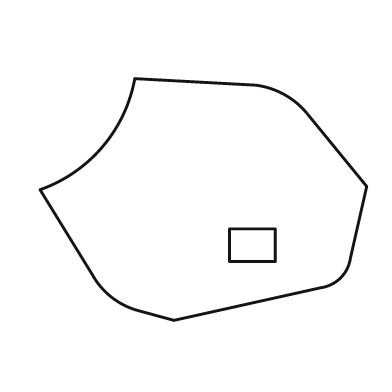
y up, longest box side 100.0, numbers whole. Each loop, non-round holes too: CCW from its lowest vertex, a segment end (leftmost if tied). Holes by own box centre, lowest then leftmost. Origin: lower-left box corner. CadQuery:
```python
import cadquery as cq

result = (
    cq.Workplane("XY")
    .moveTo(41.0, 0.0)
    .lineTo(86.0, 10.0)
    .threePointArc((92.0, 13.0), (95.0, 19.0))
    .lineTo(100.0, 41.0)
    .lineTo(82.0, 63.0)
    .threePointArc((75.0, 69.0), (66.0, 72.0))
    .lineTo(29.0, 74.0)
    .threePointArc((19.0, 53.0), (0.0, 40.0))
    .lineTo(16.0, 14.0)
    .threePointArc((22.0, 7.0), (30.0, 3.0))
    .close()
    .moveTo(58.0, 18.0)
    .lineTo(72.0, 18.0)
    .lineTo(72.0, 28.0)
    .lineTo(58.0, 28.0)
    .close()
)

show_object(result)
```